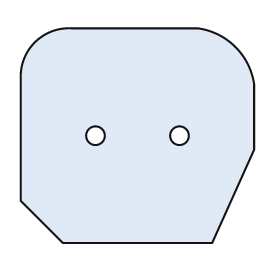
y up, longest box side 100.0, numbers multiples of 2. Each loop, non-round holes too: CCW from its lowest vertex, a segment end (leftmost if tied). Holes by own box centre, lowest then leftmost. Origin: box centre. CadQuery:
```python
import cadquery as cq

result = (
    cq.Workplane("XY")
    .moveTo(-32.0, -46.0)
    .lineTo(32.0, -46.0)
    .lineTo(50.0, -6.0)
    .lineTo(50.0, 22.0)
    .threePointArc((42.0, 38.0), (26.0, 46.0))
    .lineTo(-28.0, 46.0)
    .threePointArc((-44.0, 40.0), (-50.0, 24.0))
    .lineTo(-50.0, -28.0)
    .close()
    .moveTo(-18.0, 0.0)
    .circle(4.0)
    .moveTo(18.0, 0.0)
    .circle(4.0)
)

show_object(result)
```